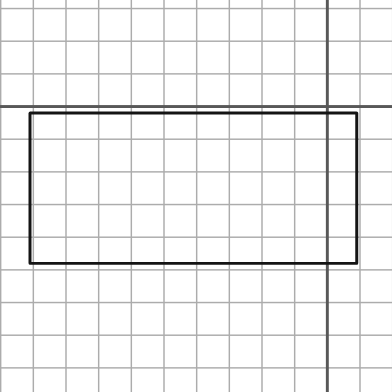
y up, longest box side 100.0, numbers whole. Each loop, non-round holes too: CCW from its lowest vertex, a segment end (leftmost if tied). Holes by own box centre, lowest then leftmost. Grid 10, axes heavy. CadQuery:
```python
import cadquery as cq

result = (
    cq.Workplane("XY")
    .moveTo(-91.0, -48.0)
    .lineTo(9.0, -48.0)
    .lineTo(9.0, -2.0)
    .lineTo(-91.0, -2.0)
    .close()
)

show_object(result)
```